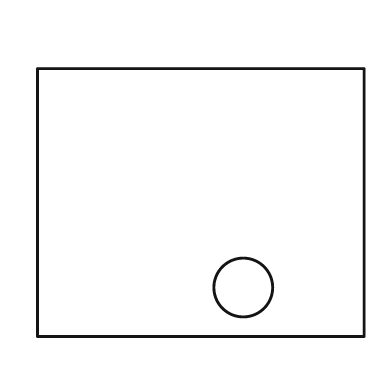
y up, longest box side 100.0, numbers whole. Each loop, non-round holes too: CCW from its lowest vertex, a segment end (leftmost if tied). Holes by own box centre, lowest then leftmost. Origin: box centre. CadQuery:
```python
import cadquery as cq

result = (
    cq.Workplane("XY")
    .moveTo(-50.0, -41.0)
    .lineTo(50.0, -41.0)
    .lineTo(50.0, 41.0)
    .lineTo(-50.0, 41.0)
    .close()
    .moveTo(13.0, -26.0)
    .circle(9.0)
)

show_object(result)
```